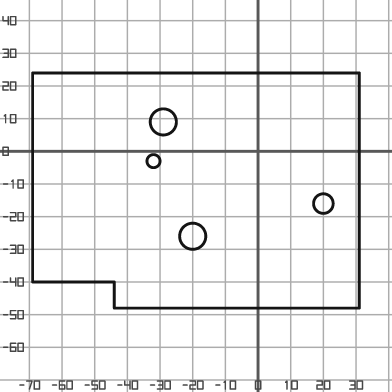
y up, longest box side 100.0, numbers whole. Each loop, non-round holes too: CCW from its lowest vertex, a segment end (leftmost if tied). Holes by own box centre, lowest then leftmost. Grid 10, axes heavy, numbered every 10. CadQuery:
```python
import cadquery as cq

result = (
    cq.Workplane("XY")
    .moveTo(-44.0, -48.0)
    .lineTo(31.0, -48.0)
    .lineTo(31.0, 24.0)
    .lineTo(-69.0, 24.0)
    .lineTo(-69.0, -40.0)
    .lineTo(-44.0, -40.0)
    .close()
    .moveTo(-20.0, -26.0)
    .circle(4.0)
    .moveTo(20.0, -16.0)
    .circle(3.0)
    .moveTo(-32.0, -3.0)
    .circle(2.0)
    .moveTo(-29.0, 9.0)
    .circle(4.0)
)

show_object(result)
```